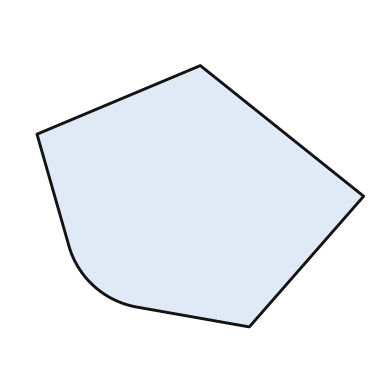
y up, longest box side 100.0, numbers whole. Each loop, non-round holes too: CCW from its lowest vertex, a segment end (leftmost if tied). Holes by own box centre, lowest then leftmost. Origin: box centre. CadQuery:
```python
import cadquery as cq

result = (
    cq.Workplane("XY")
    .moveTo(15.0, -40.0)
    .lineTo(50.0, 0.0)
    .lineTo(0.0, 40.0)
    .lineTo(-50.0, 19.0)
    .lineTo(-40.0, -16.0)
    .threePointArc((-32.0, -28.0), (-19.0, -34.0))
    .close()
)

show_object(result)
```